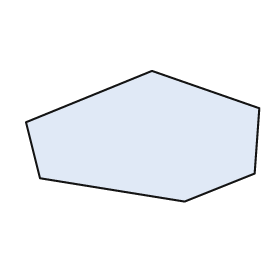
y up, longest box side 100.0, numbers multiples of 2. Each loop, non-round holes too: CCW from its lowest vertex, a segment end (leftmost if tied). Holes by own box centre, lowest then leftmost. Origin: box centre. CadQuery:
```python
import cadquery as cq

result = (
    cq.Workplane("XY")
    .moveTo(18.0, -28.0)
    .lineTo(48.0, -16.0)
    .lineTo(50.0, 12.0)
    .lineTo(4.0, 28.0)
    .lineTo(-50.0, 6.0)
    .lineTo(-44.0, -18.0)
    .close()
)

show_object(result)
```